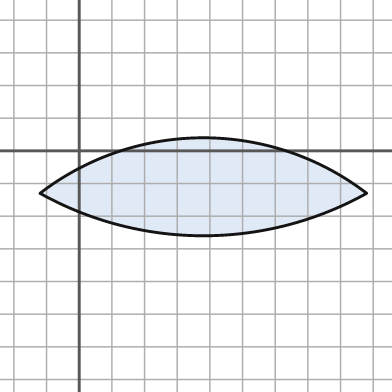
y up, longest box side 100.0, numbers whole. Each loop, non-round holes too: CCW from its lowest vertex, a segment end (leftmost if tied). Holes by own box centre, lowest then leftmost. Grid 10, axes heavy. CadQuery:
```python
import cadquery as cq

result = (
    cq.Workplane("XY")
    .moveTo(-12.0, -13.0)
    .threePointArc((38.0, -26.0), (88.0, -13.0))
    .threePointArc((38.0, 4.0), (-12.0, -13.0))
    .close()
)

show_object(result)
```